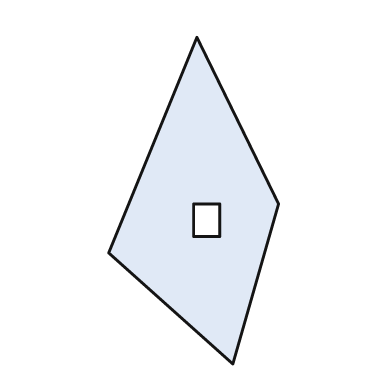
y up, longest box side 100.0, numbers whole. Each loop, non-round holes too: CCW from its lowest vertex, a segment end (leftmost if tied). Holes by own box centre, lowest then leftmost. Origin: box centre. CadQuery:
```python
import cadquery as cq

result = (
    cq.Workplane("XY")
    .moveTo(12.0, -50.0)
    .lineTo(26.0, -1.0)
    .lineTo(1.0, 50.0)
    .lineTo(-26.0, -16.0)
    .close()
    .moveTo(0.0, -11.0)
    .lineTo(8.0, -11.0)
    .lineTo(8.0, -1.0)
    .lineTo(0.0, -1.0)
    .close()
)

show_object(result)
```